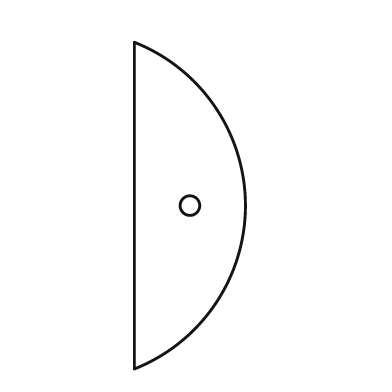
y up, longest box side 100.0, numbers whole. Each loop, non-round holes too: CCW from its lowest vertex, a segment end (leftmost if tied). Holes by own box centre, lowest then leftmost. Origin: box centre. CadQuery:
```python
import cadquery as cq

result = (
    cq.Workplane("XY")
    .moveTo(-17.0, -50.0)
    .threePointArc((17.0, 0.0), (-17.0, 50.0))
    .close()
    .moveTo(0.0, 0.0)
    .circle(3.0)
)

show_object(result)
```